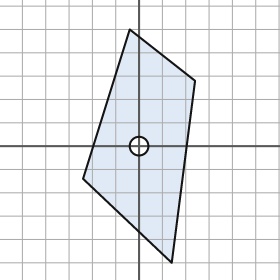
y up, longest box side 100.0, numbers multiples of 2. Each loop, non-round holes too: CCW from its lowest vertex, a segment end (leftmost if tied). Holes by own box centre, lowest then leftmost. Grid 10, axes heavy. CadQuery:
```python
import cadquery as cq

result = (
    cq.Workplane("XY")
    .moveTo(14.0, -50.0)
    .lineTo(24.0, 28.0)
    .lineTo(-4.0, 50.0)
    .lineTo(-24.0, -14.0)
    .close()
    .moveTo(0.0, 0.0)
    .circle(4.0)
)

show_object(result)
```